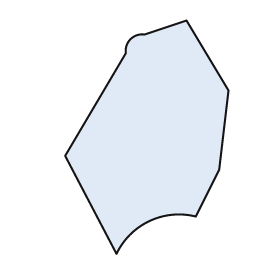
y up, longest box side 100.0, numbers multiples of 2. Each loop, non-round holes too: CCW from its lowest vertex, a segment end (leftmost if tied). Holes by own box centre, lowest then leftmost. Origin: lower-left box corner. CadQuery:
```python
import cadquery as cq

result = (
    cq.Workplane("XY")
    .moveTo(22.0, 0.0)
    .threePointArc((36.0, 14.0), (56.0, 16.0))
    .lineTo(66.0, 36.0)
    .lineTo(70.0, 70.0)
    .lineTo(52.0, 100.0)
    .lineTo(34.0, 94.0)
    .threePointArc((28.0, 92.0), (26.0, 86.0))
    .lineTo(0.0, 42.0)
    .close()
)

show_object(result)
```